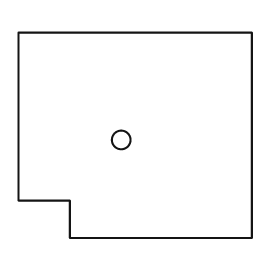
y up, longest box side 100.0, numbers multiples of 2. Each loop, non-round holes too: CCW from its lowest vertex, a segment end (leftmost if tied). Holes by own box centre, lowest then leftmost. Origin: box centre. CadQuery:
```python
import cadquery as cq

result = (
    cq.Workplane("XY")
    .moveTo(-28.0, -44.0)
    .lineTo(50.0, -44.0)
    .lineTo(50.0, 44.0)
    .lineTo(-50.0, 44.0)
    .lineTo(-50.0, -28.0)
    .lineTo(-28.0, -28.0)
    .close()
    .moveTo(-6.0, -2.0)
    .circle(4.0)
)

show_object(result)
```